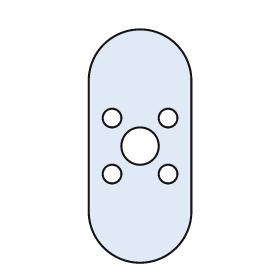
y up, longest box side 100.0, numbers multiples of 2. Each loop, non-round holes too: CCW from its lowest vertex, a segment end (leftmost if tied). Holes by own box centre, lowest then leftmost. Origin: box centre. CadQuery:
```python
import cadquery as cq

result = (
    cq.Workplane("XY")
    .moveTo(-22.0, -28.0)
    .threePointArc((0.0, -50.0), (22.0, -28.0))
    .lineTo(22.0, 28.0)
    .threePointArc((0.0, 50.0), (-22.0, 28.0))
    .close()
    .moveTo(-12.0, -12.0)
    .circle(4.0)
    .moveTo(12.0, -12.0)
    .circle(4.0)
    .moveTo(0.0, 0.0)
    .circle(8.0)
    .moveTo(-12.0, 12.0)
    .circle(4.0)
    .moveTo(12.0, 12.0)
    .circle(4.0)
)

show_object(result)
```